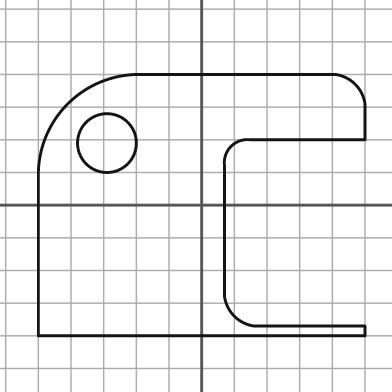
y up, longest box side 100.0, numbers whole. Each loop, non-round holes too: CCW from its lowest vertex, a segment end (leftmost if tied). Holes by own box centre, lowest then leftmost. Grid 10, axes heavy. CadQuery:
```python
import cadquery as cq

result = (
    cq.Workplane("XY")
    .moveTo(-50.0, -40.0)
    .lineTo(50.0, -40.0)
    .lineTo(50.0, -37.0)
    .lineTo(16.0, -37.0)
    .threePointArc((10.0, -34.0), (7.0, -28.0))
    .lineTo(7.0, 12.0)
    .threePointArc((9.0, 18.0), (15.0, 20.0))
    .lineTo(50.0, 20.0)
    .lineTo(50.0, 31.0)
    .threePointArc((47.0, 37.0), (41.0, 40.0))
    .lineTo(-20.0, 40.0)
    .threePointArc((-41.0, 31.0), (-50.0, 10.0))
    .close()
    .moveTo(-29.0, 19.0)
    .circle(9.0)
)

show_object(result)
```